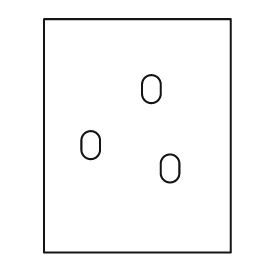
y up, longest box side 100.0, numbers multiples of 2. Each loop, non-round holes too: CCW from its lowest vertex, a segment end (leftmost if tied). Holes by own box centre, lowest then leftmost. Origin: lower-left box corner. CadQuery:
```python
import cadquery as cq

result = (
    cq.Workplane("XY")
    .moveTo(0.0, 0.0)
    .lineTo(80.0, 0.0)
    .lineTo(80.0, 100.0)
    .lineTo(0.0, 100.0)
    .close()
    .moveTo(50.0, 34.0)
    .threePointArc((54.0, 30.0), (58.0, 34.0))
    .lineTo(58.0, 38.0)
    .threePointArc((54.0, 42.0), (50.0, 38.0))
    .close()
    .moveTo(16.0, 44.0)
    .threePointArc((20.0, 40.0), (24.0, 44.0))
    .lineTo(24.0, 48.0)
    .threePointArc((20.0, 52.0), (16.0, 48.0))
    .close()
    .moveTo(42.0, 68.0)
    .threePointArc((46.0, 64.0), (50.0, 68.0))
    .lineTo(50.0, 72.0)
    .threePointArc((46.0, 76.0), (42.0, 72.0))
    .close()
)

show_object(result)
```